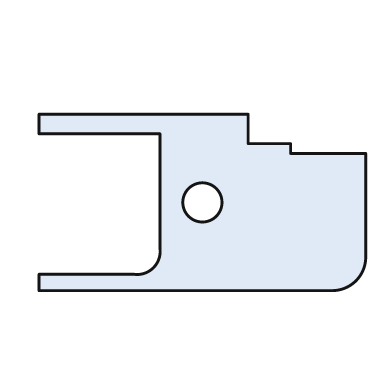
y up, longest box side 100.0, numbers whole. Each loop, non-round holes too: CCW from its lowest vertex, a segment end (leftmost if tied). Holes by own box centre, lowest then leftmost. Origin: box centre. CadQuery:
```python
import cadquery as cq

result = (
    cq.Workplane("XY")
    .moveTo(-50.0, -27.0)
    .lineTo(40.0, -27.0)
    .threePointArc((47.0, -24.0), (50.0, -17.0))
    .lineTo(50.0, 15.0)
    .lineTo(27.0, 15.0)
    .lineTo(27.0, 18.0)
    .lineTo(14.0, 18.0)
    .lineTo(14.0, 27.0)
    .lineTo(-50.0, 27.0)
    .lineTo(-50.0, 21.0)
    .lineTo(-13.0, 21.0)
    .lineTo(-13.0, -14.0)
    .threePointArc((-15.0, -20.0), (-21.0, -22.0))
    .lineTo(-50.0, -22.0)
    .close()
    .moveTo(0.0, 0.0)
    .circle(6.0)
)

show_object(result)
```